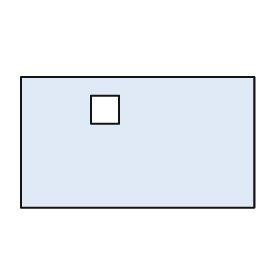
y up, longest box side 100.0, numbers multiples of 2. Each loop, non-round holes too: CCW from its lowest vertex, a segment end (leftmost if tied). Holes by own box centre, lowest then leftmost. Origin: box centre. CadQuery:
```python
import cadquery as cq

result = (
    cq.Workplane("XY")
    .moveTo(-50.0, -28.0)
    .lineTo(50.0, -28.0)
    .lineTo(50.0, 28.0)
    .lineTo(-50.0, 28.0)
    .close()
    .moveTo(-20.0, 8.0)
    .lineTo(-8.0, 8.0)
    .lineTo(-8.0, 20.0)
    .lineTo(-20.0, 20.0)
    .close()
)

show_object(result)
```